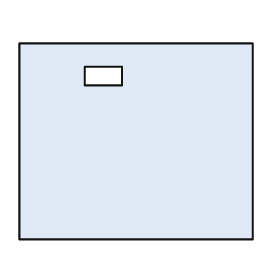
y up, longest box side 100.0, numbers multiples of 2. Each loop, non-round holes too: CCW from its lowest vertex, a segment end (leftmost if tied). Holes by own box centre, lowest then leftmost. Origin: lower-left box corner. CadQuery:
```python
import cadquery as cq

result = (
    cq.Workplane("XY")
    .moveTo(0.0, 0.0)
    .lineTo(100.0, 0.0)
    .lineTo(100.0, 84.0)
    .lineTo(0.0, 84.0)
    .close()
    .moveTo(28.0, 66.0)
    .lineTo(44.0, 66.0)
    .lineTo(44.0, 74.0)
    .lineTo(28.0, 74.0)
    .close()
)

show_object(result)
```